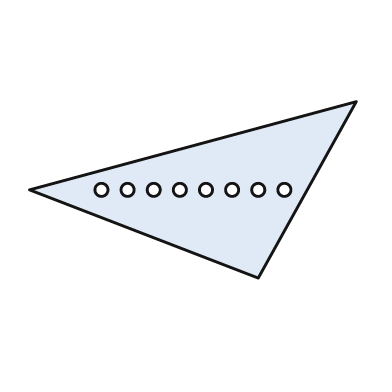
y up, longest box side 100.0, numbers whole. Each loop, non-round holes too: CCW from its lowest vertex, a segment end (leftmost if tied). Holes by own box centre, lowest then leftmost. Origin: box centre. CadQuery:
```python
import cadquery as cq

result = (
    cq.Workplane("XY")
    .moveTo(20.0, -27.0)
    .lineTo(50.0, 27.0)
    .lineTo(-50.0, 0.0)
    .close()
    .moveTo(-28.0, 0.0)
    .circle(2.0)
    .moveTo(-20.0, 0.0)
    .circle(2.0)
    .moveTo(-12.0, 0.0)
    .circle(2.0)
    .moveTo(-4.0, 0.0)
    .circle(2.0)
    .moveTo(4.0, 0.0)
    .circle(2.0)
    .moveTo(12.0, 0.0)
    .circle(2.0)
    .moveTo(20.0, 0.0)
    .circle(2.0)
    .moveTo(28.0, 0.0)
    .circle(2.0)
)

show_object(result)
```